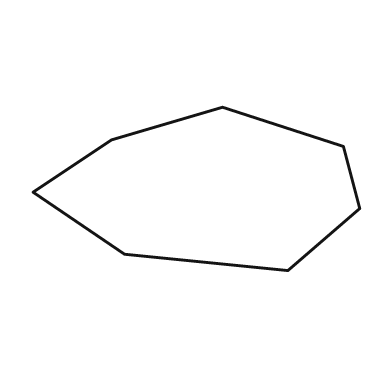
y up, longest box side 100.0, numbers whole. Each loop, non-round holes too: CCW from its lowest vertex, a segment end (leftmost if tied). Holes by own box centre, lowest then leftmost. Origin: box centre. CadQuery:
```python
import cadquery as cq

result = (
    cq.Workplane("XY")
    .moveTo(28.0, -25.0)
    .lineTo(50.0, -6.0)
    .lineTo(45.0, 13.0)
    .lineTo(8.0, 25.0)
    .lineTo(-26.0, 15.0)
    .lineTo(-50.0, -1.0)
    .lineTo(-22.0, -20.0)
    .close()
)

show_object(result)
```